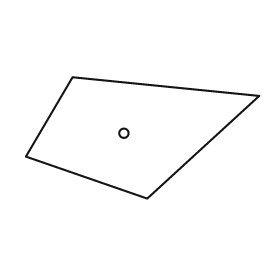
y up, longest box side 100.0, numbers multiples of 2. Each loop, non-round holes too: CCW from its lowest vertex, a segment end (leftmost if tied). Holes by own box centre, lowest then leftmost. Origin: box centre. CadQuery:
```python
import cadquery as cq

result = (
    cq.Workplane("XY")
    .moveTo(2.0, -26.0)
    .lineTo(50.0, 18.0)
    .lineTo(-30.0, 26.0)
    .lineTo(-50.0, -8.0)
    .close()
    .moveTo(-8.0, 2.0)
    .circle(2.0)
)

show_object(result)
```